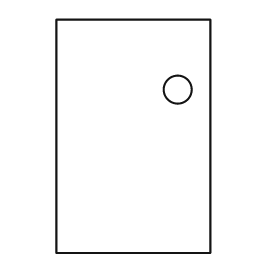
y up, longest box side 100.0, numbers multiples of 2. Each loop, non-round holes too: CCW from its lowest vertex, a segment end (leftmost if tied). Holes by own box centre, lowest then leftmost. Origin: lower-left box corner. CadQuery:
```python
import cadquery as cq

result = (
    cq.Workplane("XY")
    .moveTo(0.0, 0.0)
    .lineTo(66.0, 0.0)
    .lineTo(66.0, 100.0)
    .lineTo(0.0, 100.0)
    .close()
    .moveTo(52.0, 70.0)
    .circle(6.0)
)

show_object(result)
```